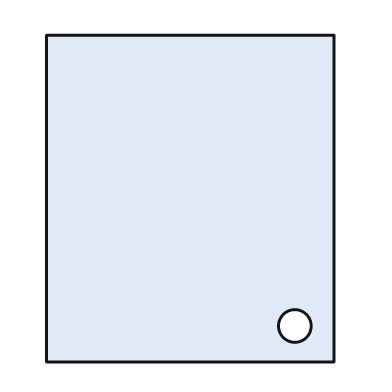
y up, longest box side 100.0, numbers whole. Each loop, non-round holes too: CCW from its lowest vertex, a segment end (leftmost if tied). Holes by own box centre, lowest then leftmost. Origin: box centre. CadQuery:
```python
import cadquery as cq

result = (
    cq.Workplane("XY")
    .moveTo(-44.0, -50.0)
    .lineTo(44.0, -50.0)
    .lineTo(44.0, 50.0)
    .lineTo(-44.0, 50.0)
    .close()
    .moveTo(32.0, -39.0)
    .circle(5.0)
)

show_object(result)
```